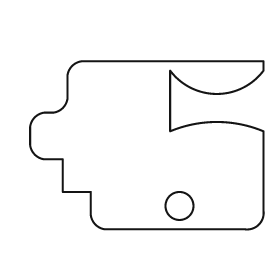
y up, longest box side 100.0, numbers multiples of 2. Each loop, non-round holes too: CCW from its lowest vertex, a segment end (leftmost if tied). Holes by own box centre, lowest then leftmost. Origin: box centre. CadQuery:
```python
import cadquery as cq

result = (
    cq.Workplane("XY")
    .moveTo(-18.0, -36.0)
    .lineTo(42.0, -36.0)
    .threePointArc((48.0, -34.0), (50.0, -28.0))
    .lineTo(50.0, 6.0)
    .threePointArc((30.0, 10.0), (10.0, 6.0))
    .lineTo(10.0, 32.0)
    .threePointArc((30.0, 22.0), (50.0, 32.0))
    .lineTo(50.0, 36.0)
    .lineTo(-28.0, 36.0)
    .threePointArc((-32.0, 34.0), (-34.0, 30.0))
    .lineTo(-34.0, 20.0)
    .threePointArc((-36.0, 16.0), (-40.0, 14.0))
    .lineTo(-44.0, 14.0)
    .threePointArc((-48.0, 12.0), (-50.0, 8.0))
    .lineTo(-50.0, 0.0)
    .threePointArc((-48.0, -4.0), (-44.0, -6.0))
    .lineTo(-36.0, -6.0)
    .lineTo(-36.0, -20.0)
    .lineTo(-24.0, -20.0)
    .lineTo(-24.0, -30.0)
    .threePointArc((-22.0, -34.0), (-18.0, -36.0))
    .close()
    .moveTo(14.0, -26.0)
    .circle(6.0)
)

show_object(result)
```